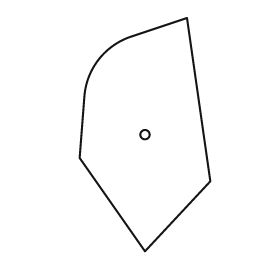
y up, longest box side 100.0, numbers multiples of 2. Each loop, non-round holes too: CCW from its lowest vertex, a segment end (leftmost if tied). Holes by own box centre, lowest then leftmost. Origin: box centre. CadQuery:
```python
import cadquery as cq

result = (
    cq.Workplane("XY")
    .moveTo(0.0, -50.0)
    .lineTo(28.0, -20.0)
    .lineTo(18.0, 50.0)
    .lineTo(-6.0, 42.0)
    .threePointArc((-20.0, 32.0), (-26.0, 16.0))
    .lineTo(-28.0, -10.0)
    .close()
    .moveTo(0.0, 0.0)
    .circle(2.0)
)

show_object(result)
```